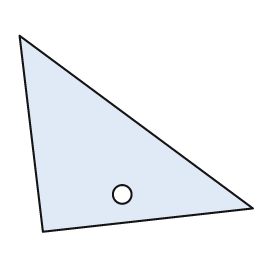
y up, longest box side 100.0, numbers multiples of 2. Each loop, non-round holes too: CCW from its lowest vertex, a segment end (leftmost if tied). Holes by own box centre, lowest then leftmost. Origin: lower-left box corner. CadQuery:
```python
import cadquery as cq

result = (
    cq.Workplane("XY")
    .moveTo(10.0, 0.0)
    .lineTo(100.0, 10.0)
    .lineTo(0.0, 84.0)
    .close()
    .moveTo(44.0, 16.0)
    .circle(4.0)
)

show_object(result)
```